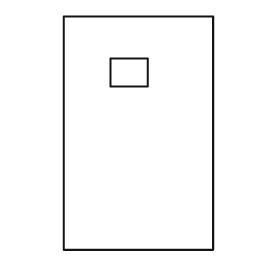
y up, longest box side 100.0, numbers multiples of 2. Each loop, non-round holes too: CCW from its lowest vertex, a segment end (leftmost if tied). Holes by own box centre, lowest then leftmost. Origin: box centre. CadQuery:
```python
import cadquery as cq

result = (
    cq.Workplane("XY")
    .moveTo(-32.0, -50.0)
    .lineTo(32.0, -50.0)
    .lineTo(32.0, 50.0)
    .lineTo(-32.0, 50.0)
    .close()
    .moveTo(-12.0, 20.0)
    .lineTo(4.0, 20.0)
    .lineTo(4.0, 32.0)
    .lineTo(-12.0, 32.0)
    .close()
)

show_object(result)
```